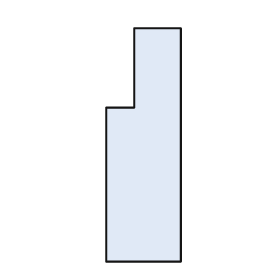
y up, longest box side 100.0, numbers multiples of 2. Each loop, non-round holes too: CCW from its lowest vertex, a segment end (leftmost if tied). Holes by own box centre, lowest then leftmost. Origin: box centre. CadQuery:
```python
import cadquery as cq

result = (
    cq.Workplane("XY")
    .moveTo(-16.0, -50.0)
    .lineTo(16.0, -50.0)
    .lineTo(16.0, 50.0)
    .lineTo(-4.0, 50.0)
    .lineTo(-4.0, 16.0)
    .lineTo(-16.0, 16.0)
    .close()
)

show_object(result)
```